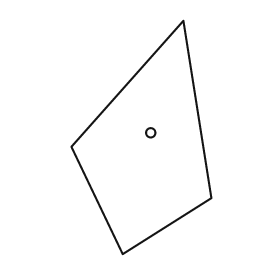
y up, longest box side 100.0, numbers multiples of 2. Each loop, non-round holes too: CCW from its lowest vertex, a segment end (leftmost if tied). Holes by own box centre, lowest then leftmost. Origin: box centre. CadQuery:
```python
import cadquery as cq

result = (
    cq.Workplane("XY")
    .moveTo(-8.0, -50.0)
    .lineTo(30.0, -26.0)
    .lineTo(18.0, 50.0)
    .lineTo(-30.0, -4.0)
    .close()
    .moveTo(4.0, 2.0)
    .circle(2.0)
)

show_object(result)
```